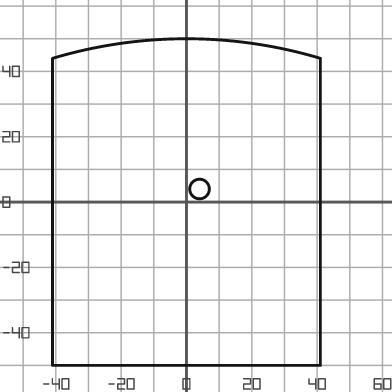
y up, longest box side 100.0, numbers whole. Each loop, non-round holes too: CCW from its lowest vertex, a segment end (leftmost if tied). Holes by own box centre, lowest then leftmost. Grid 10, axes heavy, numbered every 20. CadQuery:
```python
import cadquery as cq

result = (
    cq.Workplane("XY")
    .moveTo(-41.0, -50.0)
    .lineTo(41.0, -50.0)
    .lineTo(41.0, 44.0)
    .threePointArc((0.0, 50.0), (-41.0, 44.0))
    .close()
    .moveTo(4.0, 4.0)
    .circle(3.0)
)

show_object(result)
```